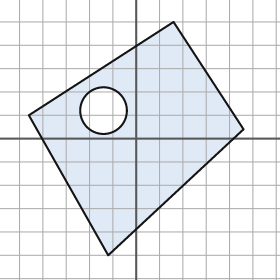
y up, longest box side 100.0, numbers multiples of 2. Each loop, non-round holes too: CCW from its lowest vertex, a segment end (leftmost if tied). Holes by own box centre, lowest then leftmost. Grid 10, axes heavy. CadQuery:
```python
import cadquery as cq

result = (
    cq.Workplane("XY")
    .moveTo(-12.0, -50.0)
    .lineTo(46.0, 4.0)
    .lineTo(16.0, 50.0)
    .lineTo(-46.0, 10.0)
    .close()
    .moveTo(-14.0, 12.0)
    .circle(10.0)
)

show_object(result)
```